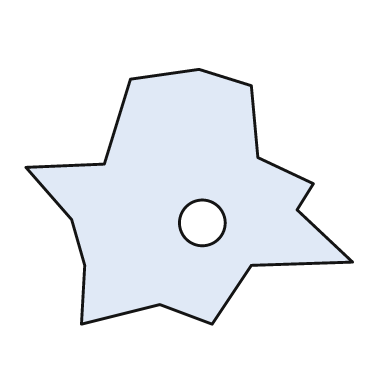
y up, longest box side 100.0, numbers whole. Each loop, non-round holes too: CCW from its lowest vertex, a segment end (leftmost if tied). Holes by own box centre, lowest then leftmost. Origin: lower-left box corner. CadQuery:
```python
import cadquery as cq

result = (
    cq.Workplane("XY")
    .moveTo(17.0, 0.0)
    .lineTo(41.0, 6.0)
    .lineTo(57.0, 0.0)
    .lineTo(69.0, 18.0)
    .lineTo(100.0, 19.0)
    .lineTo(83.0, 35.0)
    .lineTo(88.0, 43.0)
    .lineTo(71.0, 51.0)
    .lineTo(69.0, 73.0)
    .lineTo(53.0, 78.0)
    .lineTo(32.0, 75.0)
    .lineTo(24.0, 49.0)
    .lineTo(0.0, 48.0)
    .lineTo(14.0, 32.0)
    .lineTo(18.0, 18.0)
    .close()
    .moveTo(54.0, 31.0)
    .circle(7.0)
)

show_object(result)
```